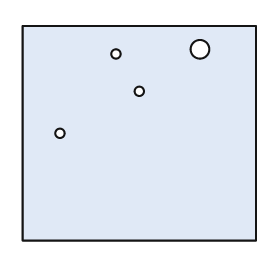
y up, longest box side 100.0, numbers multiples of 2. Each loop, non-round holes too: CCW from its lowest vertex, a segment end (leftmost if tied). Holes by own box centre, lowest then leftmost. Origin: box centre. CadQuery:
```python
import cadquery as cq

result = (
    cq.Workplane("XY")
    .moveTo(-50.0, -46.0)
    .lineTo(50.0, -46.0)
    .lineTo(50.0, 46.0)
    .lineTo(-50.0, 46.0)
    .close()
    .moveTo(-34.0, 0.0)
    .circle(2.0)
    .moveTo(0.0, 18.0)
    .circle(2.0)
    .moveTo(-10.0, 34.0)
    .circle(2.0)
    .moveTo(26.0, 36.0)
    .circle(4.0)
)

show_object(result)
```